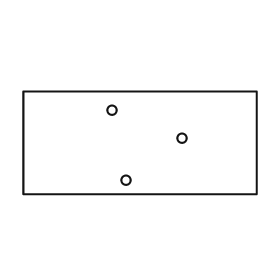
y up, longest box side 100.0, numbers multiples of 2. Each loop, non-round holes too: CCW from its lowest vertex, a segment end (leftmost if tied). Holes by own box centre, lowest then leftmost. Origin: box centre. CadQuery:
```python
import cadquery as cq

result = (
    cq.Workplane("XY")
    .moveTo(-50.0, -22.0)
    .lineTo(50.0, -22.0)
    .lineTo(50.0, 22.0)
    .lineTo(-50.0, 22.0)
    .close()
    .moveTo(-6.0, -16.0)
    .circle(2.0)
    .moveTo(18.0, 2.0)
    .circle(2.0)
    .moveTo(-12.0, 14.0)
    .circle(2.0)
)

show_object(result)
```